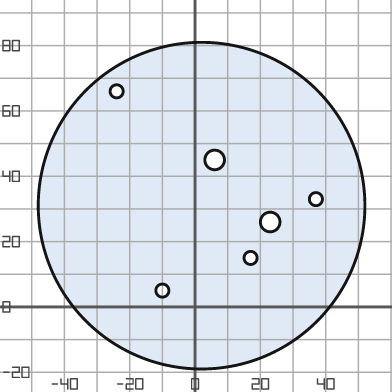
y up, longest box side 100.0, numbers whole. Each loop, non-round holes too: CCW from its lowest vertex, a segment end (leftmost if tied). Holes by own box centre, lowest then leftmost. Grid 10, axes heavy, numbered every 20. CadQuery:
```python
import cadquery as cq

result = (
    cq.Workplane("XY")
    .moveTo(2.0, 31.0)
    .circle(50.0)
    .moveTo(-10.0, 5.0)
    .circle(2.0)
    .moveTo(17.0, 15.0)
    .circle(2.0)
    .moveTo(23.0, 26.0)
    .circle(3.0)
    .moveTo(37.0, 33.0)
    .circle(2.0)
    .moveTo(6.0, 45.0)
    .circle(3.0)
    .moveTo(-24.0, 66.0)
    .circle(2.0)
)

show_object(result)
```